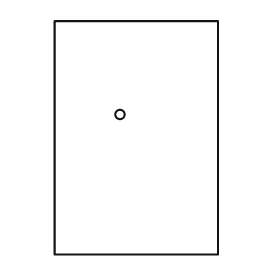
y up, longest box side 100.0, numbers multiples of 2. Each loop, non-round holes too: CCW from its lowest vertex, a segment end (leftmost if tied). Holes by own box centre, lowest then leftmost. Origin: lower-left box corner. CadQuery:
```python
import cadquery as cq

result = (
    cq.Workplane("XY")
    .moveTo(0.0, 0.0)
    .lineTo(70.0, 0.0)
    .lineTo(70.0, 100.0)
    .lineTo(0.0, 100.0)
    .close()
    .moveTo(28.0, 60.0)
    .circle(2.0)
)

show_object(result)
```